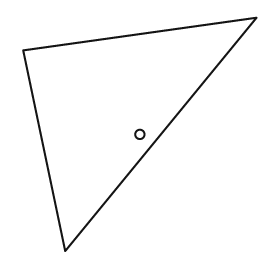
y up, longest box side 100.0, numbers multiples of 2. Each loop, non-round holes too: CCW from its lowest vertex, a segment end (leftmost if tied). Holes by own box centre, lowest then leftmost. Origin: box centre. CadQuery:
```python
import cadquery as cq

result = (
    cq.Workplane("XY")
    .moveTo(-32.0, -50.0)
    .lineTo(50.0, 50.0)
    .lineTo(-50.0, 36.0)
    .close()
    .moveTo(0.0, 0.0)
    .circle(2.0)
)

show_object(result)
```